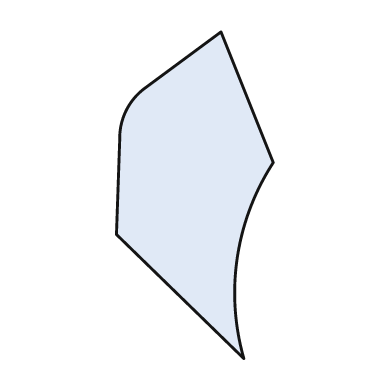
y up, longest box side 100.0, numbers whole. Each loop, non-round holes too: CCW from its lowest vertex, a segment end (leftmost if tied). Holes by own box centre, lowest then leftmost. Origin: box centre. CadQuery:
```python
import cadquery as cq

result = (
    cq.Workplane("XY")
    .moveTo(15.0, -50.0)
    .threePointArc((13.0, -19.0), (24.0, 10.0))
    .lineTo(8.0, 50.0)
    .lineTo(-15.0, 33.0)
    .threePointArc((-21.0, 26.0), (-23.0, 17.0))
    .lineTo(-24.0, -12.0)
    .close()
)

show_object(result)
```